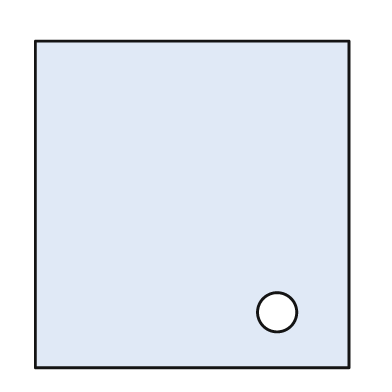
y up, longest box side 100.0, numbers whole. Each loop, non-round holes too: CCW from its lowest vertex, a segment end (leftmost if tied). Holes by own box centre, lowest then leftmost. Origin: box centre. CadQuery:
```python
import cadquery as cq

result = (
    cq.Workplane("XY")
    .moveTo(-48.0, -50.0)
    .lineTo(48.0, -50.0)
    .lineTo(48.0, 50.0)
    .lineTo(-48.0, 50.0)
    .close()
    .moveTo(26.0, -33.0)
    .circle(6.0)
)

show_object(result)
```